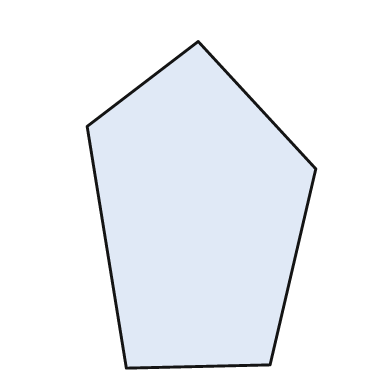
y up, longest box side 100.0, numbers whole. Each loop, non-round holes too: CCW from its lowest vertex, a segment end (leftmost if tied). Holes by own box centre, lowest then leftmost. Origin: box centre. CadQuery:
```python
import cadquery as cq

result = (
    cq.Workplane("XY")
    .moveTo(-23.0, -50.0)
    .lineTo(21.0, -49.0)
    .lineTo(35.0, 11.0)
    .lineTo(-1.0, 50.0)
    .lineTo(-35.0, 24.0)
    .close()
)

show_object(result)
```